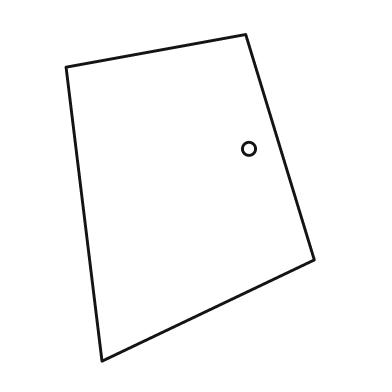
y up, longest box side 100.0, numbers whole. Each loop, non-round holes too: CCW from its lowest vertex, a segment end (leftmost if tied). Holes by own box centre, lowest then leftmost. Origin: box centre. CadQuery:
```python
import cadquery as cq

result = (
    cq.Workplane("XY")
    .moveTo(-27.0, -50.0)
    .lineTo(38.0, -19.0)
    .lineTo(17.0, 50.0)
    .lineTo(-38.0, 40.0)
    .close()
    .moveTo(18.0, 15.0)
    .circle(2.0)
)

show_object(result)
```